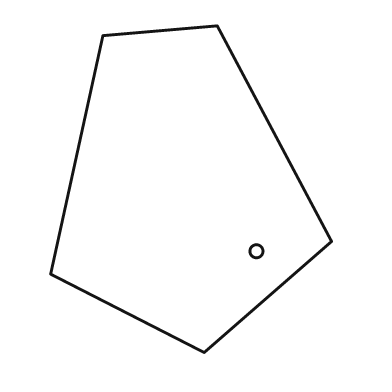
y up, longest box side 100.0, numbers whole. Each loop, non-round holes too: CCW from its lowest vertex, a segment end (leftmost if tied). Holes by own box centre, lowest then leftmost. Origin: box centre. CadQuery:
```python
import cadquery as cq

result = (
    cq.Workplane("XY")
    .moveTo(4.0, -50.0)
    .lineTo(43.0, -16.0)
    .lineTo(8.0, 50.0)
    .lineTo(-27.0, 47.0)
    .lineTo(-43.0, -26.0)
    .close()
    .moveTo(20.0, -19.0)
    .circle(2.0)
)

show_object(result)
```